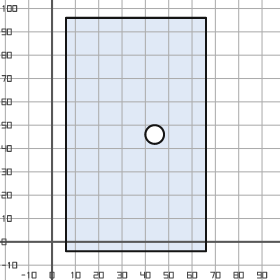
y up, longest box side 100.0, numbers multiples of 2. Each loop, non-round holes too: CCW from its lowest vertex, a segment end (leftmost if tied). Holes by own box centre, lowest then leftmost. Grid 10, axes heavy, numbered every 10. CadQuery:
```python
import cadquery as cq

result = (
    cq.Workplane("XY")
    .moveTo(6.0, -4.0)
    .lineTo(66.0, -4.0)
    .lineTo(66.0, 96.0)
    .lineTo(6.0, 96.0)
    .close()
    .moveTo(44.0, 46.0)
    .circle(4.0)
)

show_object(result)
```